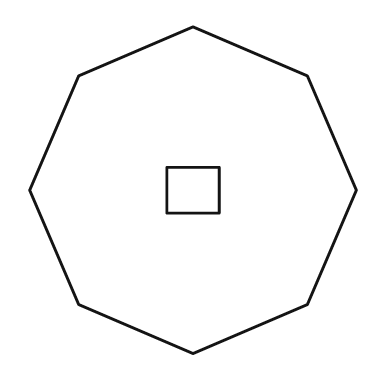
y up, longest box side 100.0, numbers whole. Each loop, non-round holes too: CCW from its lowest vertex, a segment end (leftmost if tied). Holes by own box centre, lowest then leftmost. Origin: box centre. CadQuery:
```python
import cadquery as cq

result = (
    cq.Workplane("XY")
    .moveTo(0.0, -50.0)
    .lineTo(35.0, -35.0)
    .lineTo(50.0, 0.0)
    .lineTo(35.0, 35.0)
    .lineTo(0.0, 50.0)
    .lineTo(-35.0, 35.0)
    .lineTo(-50.0, 0.0)
    .lineTo(-35.0, -35.0)
    .close()
    .moveTo(-8.0, -7.0)
    .lineTo(8.0, -7.0)
    .lineTo(8.0, 7.0)
    .lineTo(-8.0, 7.0)
    .close()
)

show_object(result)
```